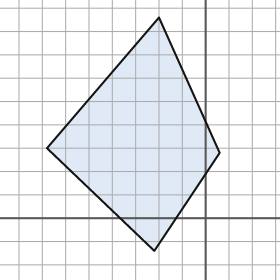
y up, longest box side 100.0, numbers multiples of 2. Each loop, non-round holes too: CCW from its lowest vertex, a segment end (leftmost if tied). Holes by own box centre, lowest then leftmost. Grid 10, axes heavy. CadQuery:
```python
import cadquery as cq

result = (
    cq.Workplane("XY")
    .moveTo(-22.0, -14.0)
    .lineTo(6.0, 28.0)
    .lineTo(-20.0, 86.0)
    .lineTo(-68.0, 30.0)
    .close()
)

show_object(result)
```